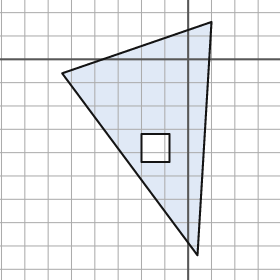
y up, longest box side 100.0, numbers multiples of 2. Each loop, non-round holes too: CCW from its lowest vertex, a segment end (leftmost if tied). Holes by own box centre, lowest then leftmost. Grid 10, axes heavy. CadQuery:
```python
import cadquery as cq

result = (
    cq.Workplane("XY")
    .moveTo(4.0, -84.0)
    .lineTo(10.0, 16.0)
    .lineTo(-54.0, -6.0)
    .close()
    .moveTo(-20.0, -44.0)
    .lineTo(-8.0, -44.0)
    .lineTo(-8.0, -32.0)
    .lineTo(-20.0, -32.0)
    .close()
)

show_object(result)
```